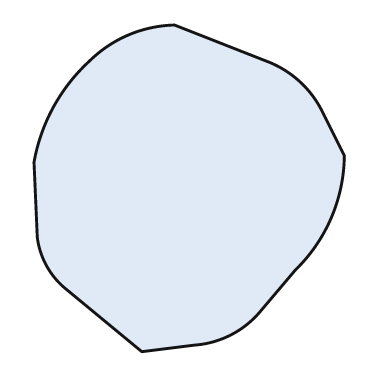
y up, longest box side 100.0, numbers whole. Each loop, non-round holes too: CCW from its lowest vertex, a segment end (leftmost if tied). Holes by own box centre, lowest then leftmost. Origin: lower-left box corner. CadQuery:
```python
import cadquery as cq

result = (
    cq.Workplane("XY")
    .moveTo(33.0, 0.0)
    .lineTo(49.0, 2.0)
    .threePointArc((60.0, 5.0), (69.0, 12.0))
    .lineTo(80.0, 25.0)
    .threePointArc((91.0, 41.0), (95.0, 60.0))
    .lineTo(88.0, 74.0)
    .threePointArc((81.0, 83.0), (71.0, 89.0))
    .lineTo(43.0, 100.0)
    .threePointArc((29.0, 97.0), (17.0, 89.0))
    .threePointArc((6.0, 75.0), (0.0, 58.0))
    .lineTo(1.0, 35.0)
    .threePointArc((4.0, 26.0), (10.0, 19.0))
    .close()
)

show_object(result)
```